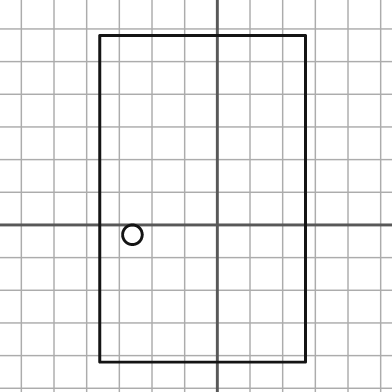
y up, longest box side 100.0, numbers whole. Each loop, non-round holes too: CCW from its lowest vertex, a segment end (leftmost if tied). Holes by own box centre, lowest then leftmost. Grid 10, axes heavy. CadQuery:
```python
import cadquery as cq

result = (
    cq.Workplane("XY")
    .moveTo(-36.0, -42.0)
    .lineTo(27.0, -42.0)
    .lineTo(27.0, 58.0)
    .lineTo(-36.0, 58.0)
    .close()
    .moveTo(-26.0, -3.0)
    .circle(3.0)
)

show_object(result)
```